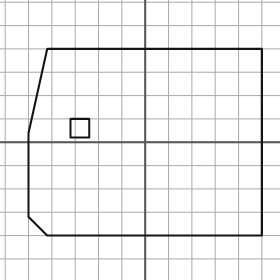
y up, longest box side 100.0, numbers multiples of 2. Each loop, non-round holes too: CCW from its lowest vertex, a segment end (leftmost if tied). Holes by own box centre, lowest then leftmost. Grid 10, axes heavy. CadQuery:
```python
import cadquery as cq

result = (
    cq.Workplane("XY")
    .moveTo(-42.0, -40.0)
    .lineTo(50.0, -40.0)
    .lineTo(50.0, 40.0)
    .lineTo(-42.0, 40.0)
    .lineTo(-50.0, 4.0)
    .lineTo(-50.0, -32.0)
    .close()
    .moveTo(-32.0, 2.0)
    .lineTo(-24.0, 2.0)
    .lineTo(-24.0, 10.0)
    .lineTo(-32.0, 10.0)
    .close()
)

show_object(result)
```